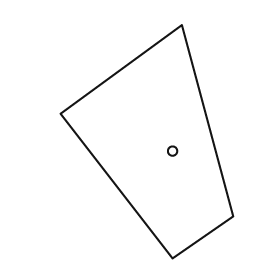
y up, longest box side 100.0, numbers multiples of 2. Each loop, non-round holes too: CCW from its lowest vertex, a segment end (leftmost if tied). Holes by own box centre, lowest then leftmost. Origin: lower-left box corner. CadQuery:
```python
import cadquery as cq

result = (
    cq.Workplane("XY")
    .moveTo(48.0, 0.0)
    .lineTo(74.0, 18.0)
    .lineTo(52.0, 100.0)
    .lineTo(0.0, 62.0)
    .close()
    .moveTo(48.0, 46.0)
    .circle(2.0)
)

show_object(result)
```